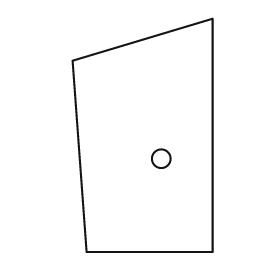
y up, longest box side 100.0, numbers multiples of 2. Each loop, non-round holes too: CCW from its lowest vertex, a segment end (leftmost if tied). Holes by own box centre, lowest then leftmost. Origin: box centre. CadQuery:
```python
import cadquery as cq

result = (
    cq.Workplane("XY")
    .moveTo(-24.0, -50.0)
    .lineTo(30.0, -50.0)
    .lineTo(30.0, 50.0)
    .lineTo(-30.0, 32.0)
    .close()
    .moveTo(8.0, -10.0)
    .circle(4.0)
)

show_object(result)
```